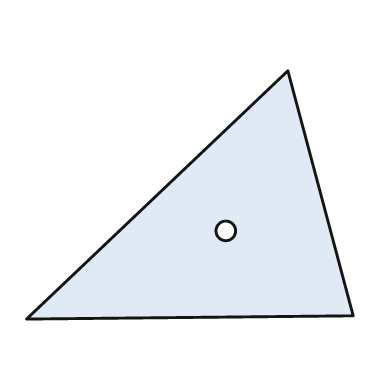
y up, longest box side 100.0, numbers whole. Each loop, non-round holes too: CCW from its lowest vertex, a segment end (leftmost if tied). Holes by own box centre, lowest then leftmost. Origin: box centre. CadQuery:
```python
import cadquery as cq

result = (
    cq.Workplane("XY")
    .moveTo(-50.0, -38.0)
    .lineTo(50.0, -37.0)
    .lineTo(30.0, 38.0)
    .close()
    .moveTo(11.0, -11.0)
    .circle(3.0)
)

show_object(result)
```